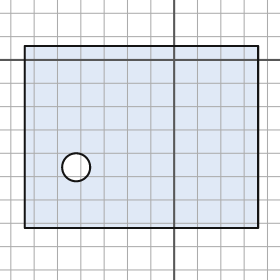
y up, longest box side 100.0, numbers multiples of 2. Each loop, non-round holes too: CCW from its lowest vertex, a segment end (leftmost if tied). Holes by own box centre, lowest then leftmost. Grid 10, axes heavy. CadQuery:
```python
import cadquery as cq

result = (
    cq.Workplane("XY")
    .moveTo(-64.0, -72.0)
    .lineTo(36.0, -72.0)
    .lineTo(36.0, 6.0)
    .lineTo(-64.0, 6.0)
    .close()
    .moveTo(-42.0, -46.0)
    .circle(6.0)
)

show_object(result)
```